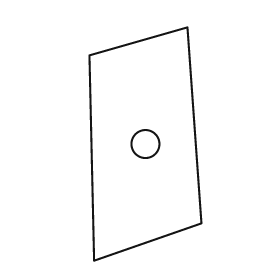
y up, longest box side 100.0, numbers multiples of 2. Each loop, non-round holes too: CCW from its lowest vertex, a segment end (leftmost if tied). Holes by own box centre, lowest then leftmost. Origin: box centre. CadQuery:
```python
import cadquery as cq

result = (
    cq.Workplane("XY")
    .moveTo(-22.0, -50.0)
    .lineTo(24.0, -34.0)
    .lineTo(18.0, 50.0)
    .lineTo(-24.0, 38.0)
    .close()
    .moveTo(0.0, 0.0)
    .circle(6.0)
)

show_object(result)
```